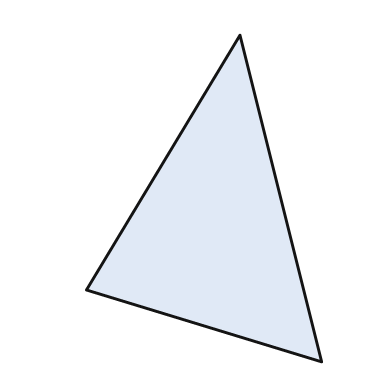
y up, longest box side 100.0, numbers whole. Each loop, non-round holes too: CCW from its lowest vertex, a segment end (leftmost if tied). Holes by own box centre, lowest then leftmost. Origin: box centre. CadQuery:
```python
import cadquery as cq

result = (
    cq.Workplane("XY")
    .moveTo(36.0, -50.0)
    .lineTo(11.0, 50.0)
    .lineTo(-36.0, -28.0)
    .close()
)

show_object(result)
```